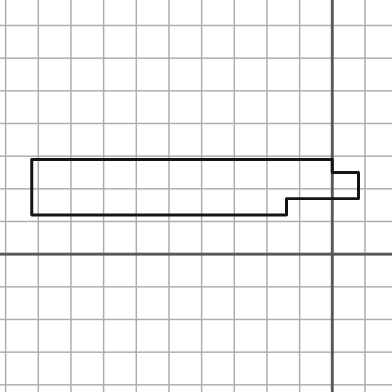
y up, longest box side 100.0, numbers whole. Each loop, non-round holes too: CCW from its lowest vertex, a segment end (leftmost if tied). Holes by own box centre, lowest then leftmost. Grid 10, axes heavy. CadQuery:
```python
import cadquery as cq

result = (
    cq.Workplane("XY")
    .moveTo(-92.0, 12.0)
    .lineTo(-14.0, 12.0)
    .lineTo(-14.0, 17.0)
    .lineTo(8.0, 17.0)
    .lineTo(8.0, 25.0)
    .lineTo(0.0, 25.0)
    .lineTo(0.0, 29.0)
    .lineTo(-92.0, 29.0)
    .close()
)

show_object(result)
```